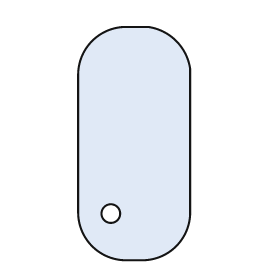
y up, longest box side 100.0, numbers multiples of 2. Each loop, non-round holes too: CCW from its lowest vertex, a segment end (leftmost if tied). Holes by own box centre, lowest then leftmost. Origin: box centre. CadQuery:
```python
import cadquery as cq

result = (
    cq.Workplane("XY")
    .moveTo(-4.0, -50.0)
    .lineTo(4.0, -50.0)
    .threePointArc((18.0, -44.0), (24.0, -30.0))
    .lineTo(24.0, 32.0)
    .threePointArc((18.0, 44.0), (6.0, 50.0))
    .lineTo(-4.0, 50.0)
    .threePointArc((-18.0, 44.0), (-24.0, 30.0))
    .lineTo(-24.0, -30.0)
    .threePointArc((-18.0, -44.0), (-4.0, -50.0))
    .close()
    .moveTo(-10.0, -30.0)
    .circle(4.0)
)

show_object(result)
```